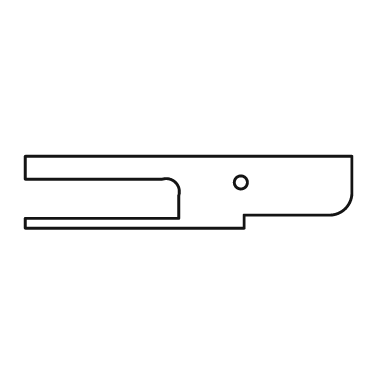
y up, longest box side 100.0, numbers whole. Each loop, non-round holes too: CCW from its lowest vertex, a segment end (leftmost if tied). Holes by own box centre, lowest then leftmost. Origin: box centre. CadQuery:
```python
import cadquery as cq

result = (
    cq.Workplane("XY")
    .moveTo(-50.0, -11.0)
    .lineTo(17.0, -11.0)
    .lineTo(17.0, -7.0)
    .lineTo(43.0, -7.0)
    .threePointArc((48.0, -5.0), (50.0, 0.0))
    .lineTo(50.0, 11.0)
    .lineTo(-50.0, 11.0)
    .lineTo(-50.0, 4.0)
    .lineTo(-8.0, 4.0)
    .threePointArc((-4.0, 3.0), (-3.0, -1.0))
    .lineTo(-3.0, -8.0)
    .lineTo(-50.0, -8.0)
    .close()
    .moveTo(16.0, 3.0)
    .circle(2.0)
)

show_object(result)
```